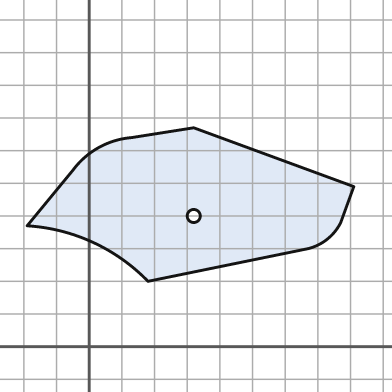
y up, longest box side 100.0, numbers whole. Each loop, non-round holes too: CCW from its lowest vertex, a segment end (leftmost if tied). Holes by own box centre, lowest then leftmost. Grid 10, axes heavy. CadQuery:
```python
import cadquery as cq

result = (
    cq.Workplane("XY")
    .moveTo(18.0, 20.0)
    .lineTo(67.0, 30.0)
    .threePointArc((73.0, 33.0), (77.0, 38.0))
    .lineTo(81.0, 49.0)
    .lineTo(32.0, 67.0)
    .lineTo(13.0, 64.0)
    .threePointArc((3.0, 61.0), (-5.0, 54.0))
    .lineTo(-19.0, 37.0)
    .threePointArc((1.0, 32.0), (18.0, 20.0))
    .close()
    .moveTo(32.0, 40.0)
    .circle(2.0)
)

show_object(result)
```